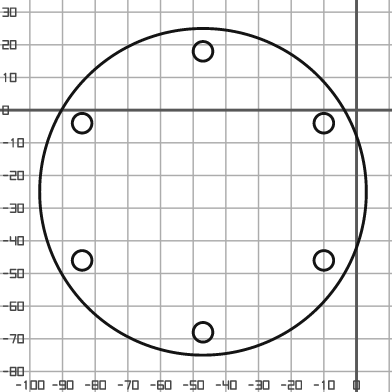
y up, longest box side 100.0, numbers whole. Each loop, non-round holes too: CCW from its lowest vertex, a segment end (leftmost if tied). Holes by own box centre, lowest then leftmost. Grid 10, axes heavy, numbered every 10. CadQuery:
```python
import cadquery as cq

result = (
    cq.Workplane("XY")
    .moveTo(-47.0, -25.0)
    .circle(50.0)
    .moveTo(-47.0, -68.0)
    .circle(3.0)
    .moveTo(-84.0, -46.0)
    .circle(3.0)
    .moveTo(-10.0, -46.0)
    .circle(3.0)
    .moveTo(-84.0, -4.0)
    .circle(3.0)
    .moveTo(-10.0, -4.0)
    .circle(3.0)
    .moveTo(-47.0, 18.0)
    .circle(3.0)
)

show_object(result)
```